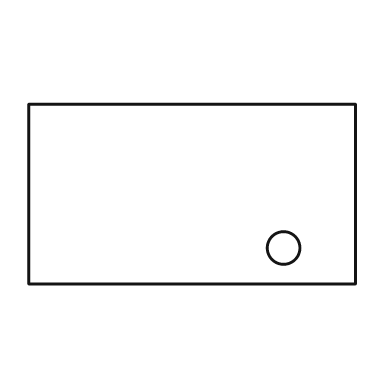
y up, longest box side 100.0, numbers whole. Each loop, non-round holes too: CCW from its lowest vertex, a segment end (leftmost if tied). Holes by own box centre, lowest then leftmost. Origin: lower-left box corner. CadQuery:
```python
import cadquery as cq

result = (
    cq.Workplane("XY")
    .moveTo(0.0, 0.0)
    .lineTo(100.0, 0.0)
    .lineTo(100.0, 55.0)
    .lineTo(0.0, 55.0)
    .close()
    .moveTo(78.0, 11.0)
    .circle(5.0)
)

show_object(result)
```